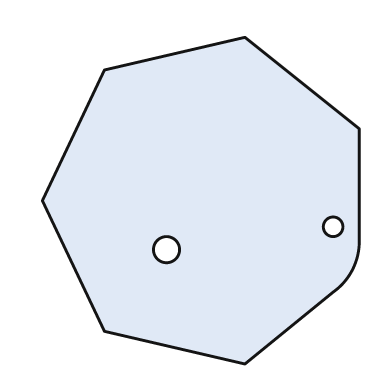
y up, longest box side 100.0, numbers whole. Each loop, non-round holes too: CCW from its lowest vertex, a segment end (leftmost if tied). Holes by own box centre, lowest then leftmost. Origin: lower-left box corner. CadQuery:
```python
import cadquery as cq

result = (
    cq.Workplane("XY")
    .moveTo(62.0, 0.0)
    .lineTo(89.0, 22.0)
    .threePointArc((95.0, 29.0), (97.0, 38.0))
    .lineTo(97.0, 72.0)
    .lineTo(62.0, 100.0)
    .lineTo(19.0, 90.0)
    .lineTo(0.0, 50.0)
    .lineTo(19.0, 10.0)
    .close()
    .moveTo(38.0, 35.0)
    .circle(4.0)
    .moveTo(89.0, 42.0)
    .circle(3.0)
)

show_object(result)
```